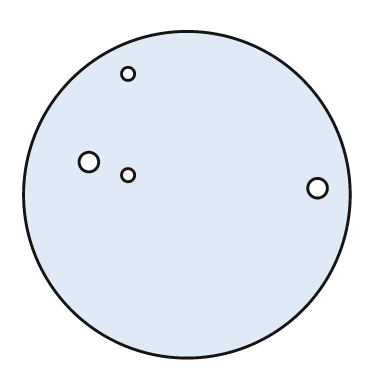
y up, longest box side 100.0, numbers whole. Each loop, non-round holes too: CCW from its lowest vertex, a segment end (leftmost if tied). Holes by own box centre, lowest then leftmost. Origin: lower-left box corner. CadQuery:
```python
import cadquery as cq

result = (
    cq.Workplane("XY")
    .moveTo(50.0, 50.0)
    .circle(50.0)
    .moveTo(90.0, 52.0)
    .circle(3.0)
    .moveTo(32.0, 56.0)
    .circle(2.0)
    .moveTo(20.0, 60.0)
    .circle(3.0)
    .moveTo(32.0, 87.0)
    .circle(2.0)
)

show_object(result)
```